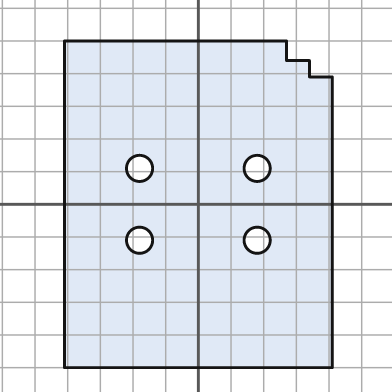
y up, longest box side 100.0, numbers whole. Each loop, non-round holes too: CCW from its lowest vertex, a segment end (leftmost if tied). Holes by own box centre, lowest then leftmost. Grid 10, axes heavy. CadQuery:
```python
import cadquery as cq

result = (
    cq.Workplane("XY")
    .moveTo(-41.0, -50.0)
    .lineTo(41.0, -50.0)
    .lineTo(41.0, 39.0)
    .lineTo(34.0, 39.0)
    .lineTo(34.0, 44.0)
    .lineTo(27.0, 44.0)
    .lineTo(27.0, 50.0)
    .lineTo(-41.0, 50.0)
    .close()
    .moveTo(-18.0, -11.0)
    .circle(4.0)
    .moveTo(18.0, -11.0)
    .circle(4.0)
    .moveTo(-18.0, 11.0)
    .circle(4.0)
    .moveTo(18.0, 11.0)
    .circle(4.0)
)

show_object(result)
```